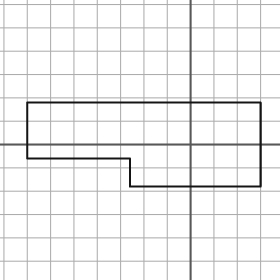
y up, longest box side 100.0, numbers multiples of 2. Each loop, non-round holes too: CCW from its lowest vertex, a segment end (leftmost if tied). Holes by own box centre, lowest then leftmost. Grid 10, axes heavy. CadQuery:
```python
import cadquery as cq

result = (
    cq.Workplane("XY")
    .moveTo(-26.0, -18.0)
    .lineTo(30.0, -18.0)
    .lineTo(30.0, 18.0)
    .lineTo(-70.0, 18.0)
    .lineTo(-70.0, -6.0)
    .lineTo(-26.0, -6.0)
    .close()
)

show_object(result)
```